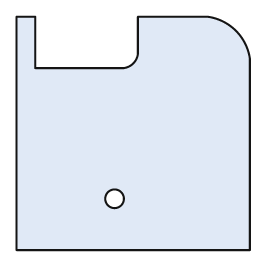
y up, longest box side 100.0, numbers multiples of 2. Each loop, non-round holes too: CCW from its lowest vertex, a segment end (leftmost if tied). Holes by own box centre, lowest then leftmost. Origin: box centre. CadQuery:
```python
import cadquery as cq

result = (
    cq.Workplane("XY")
    .moveTo(-50.0, -50.0)
    .lineTo(50.0, -50.0)
    .lineTo(50.0, 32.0)
    .threePointArc((44.0, 44.0), (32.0, 50.0))
    .lineTo(2.0, 50.0)
    .lineTo(2.0, 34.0)
    .threePointArc((0.0, 30.0), (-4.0, 28.0))
    .lineTo(-42.0, 28.0)
    .lineTo(-42.0, 50.0)
    .lineTo(-50.0, 50.0)
    .close()
    .moveTo(-8.0, -28.0)
    .circle(4.0)
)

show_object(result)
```